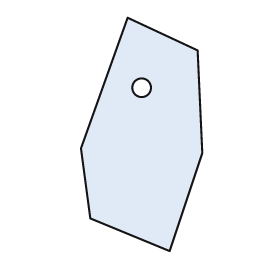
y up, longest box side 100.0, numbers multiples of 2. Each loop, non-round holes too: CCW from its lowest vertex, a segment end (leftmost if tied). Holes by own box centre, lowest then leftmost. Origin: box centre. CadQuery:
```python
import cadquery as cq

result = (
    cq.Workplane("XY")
    .moveTo(12.0, -50.0)
    .lineTo(26.0, -8.0)
    .lineTo(24.0, 36.0)
    .lineTo(-6.0, 50.0)
    .lineTo(-26.0, -6.0)
    .lineTo(-22.0, -36.0)
    .close()
    .moveTo(0.0, 20.0)
    .circle(4.0)
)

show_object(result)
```